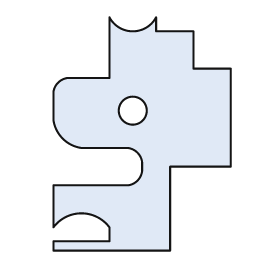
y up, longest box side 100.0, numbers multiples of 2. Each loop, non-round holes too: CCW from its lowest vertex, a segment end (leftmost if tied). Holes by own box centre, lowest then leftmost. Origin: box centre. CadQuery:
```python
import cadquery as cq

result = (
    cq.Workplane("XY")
    .moveTo(-38.0, -50.0)
    .lineTo(12.0, -50.0)
    .lineTo(12.0, -14.0)
    .lineTo(38.0, -14.0)
    .lineTo(38.0, 28.0)
    .lineTo(22.0, 28.0)
    .lineTo(22.0, 44.0)
    .lineTo(6.0, 44.0)
    .lineTo(6.0, 50.0)
    .threePointArc((-4.0, 44.0), (-14.0, 50.0))
    .lineTo(-14.0, 24.0)
    .lineTo(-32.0, 24.0)
    .threePointArc((-36.0, 22.0), (-38.0, 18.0))
    .lineTo(-38.0, 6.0)
    .threePointArc((-34.0, -2.0), (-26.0, -6.0))
    .lineTo(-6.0, -6.0)
    .threePointArc((-2.0, -8.0), (0.0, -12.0))
    .lineTo(0.0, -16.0)
    .threePointArc((-2.0, -20.0), (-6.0, -22.0))
    .lineTo(-38.0, -22.0)
    .lineTo(-38.0, -40.0)
    .threePointArc((-26.0, -34.0), (-14.0, -40.0))
    .lineTo(-14.0, -46.0)
    .lineTo(-38.0, -46.0)
    .close()
    .moveTo(-4.0, 10.0)
    .circle(6.0)
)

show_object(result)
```